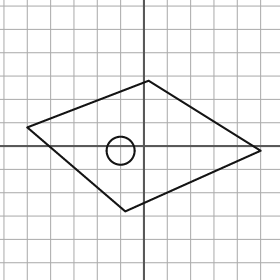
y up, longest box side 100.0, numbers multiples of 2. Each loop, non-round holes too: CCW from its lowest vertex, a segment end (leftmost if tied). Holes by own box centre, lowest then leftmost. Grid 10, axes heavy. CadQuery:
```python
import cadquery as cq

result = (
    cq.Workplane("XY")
    .moveTo(-8.0, -28.0)
    .lineTo(50.0, -2.0)
    .lineTo(2.0, 28.0)
    .lineTo(-50.0, 8.0)
    .close()
    .moveTo(-10.0, -2.0)
    .circle(6.0)
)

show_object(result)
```